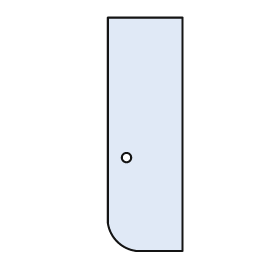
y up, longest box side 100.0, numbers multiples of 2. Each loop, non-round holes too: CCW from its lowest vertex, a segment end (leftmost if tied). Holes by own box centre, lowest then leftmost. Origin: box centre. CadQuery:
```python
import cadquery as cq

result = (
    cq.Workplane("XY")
    .moveTo(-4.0, -50.0)
    .lineTo(16.0, -50.0)
    .lineTo(16.0, 50.0)
    .lineTo(-16.0, 50.0)
    .lineTo(-16.0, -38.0)
    .threePointArc((-12.0, -46.0), (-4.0, -50.0))
    .close()
    .moveTo(-8.0, -10.0)
    .circle(2.0)
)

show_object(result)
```